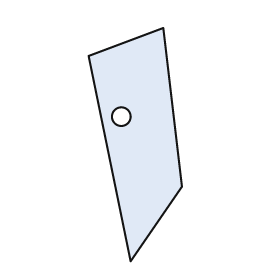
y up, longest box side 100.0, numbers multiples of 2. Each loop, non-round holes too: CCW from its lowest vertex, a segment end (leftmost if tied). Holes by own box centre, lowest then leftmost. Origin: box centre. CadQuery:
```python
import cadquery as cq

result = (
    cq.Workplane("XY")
    .moveTo(-2.0, -50.0)
    .lineTo(20.0, -18.0)
    .lineTo(12.0, 50.0)
    .lineTo(-20.0, 38.0)
    .close()
    .moveTo(-6.0, 12.0)
    .circle(4.0)
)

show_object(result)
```